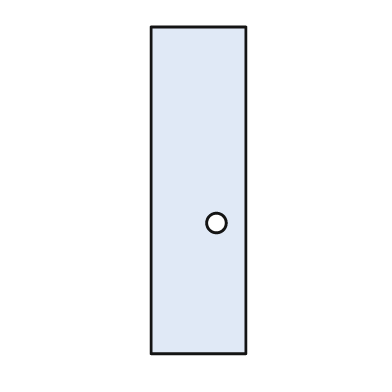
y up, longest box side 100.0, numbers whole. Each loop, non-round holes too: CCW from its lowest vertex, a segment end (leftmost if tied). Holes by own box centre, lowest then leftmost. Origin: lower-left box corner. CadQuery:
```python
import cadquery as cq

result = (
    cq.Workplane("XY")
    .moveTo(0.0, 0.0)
    .lineTo(29.0, 0.0)
    .lineTo(29.0, 100.0)
    .lineTo(0.0, 100.0)
    .close()
    .moveTo(20.0, 40.0)
    .circle(3.0)
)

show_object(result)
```